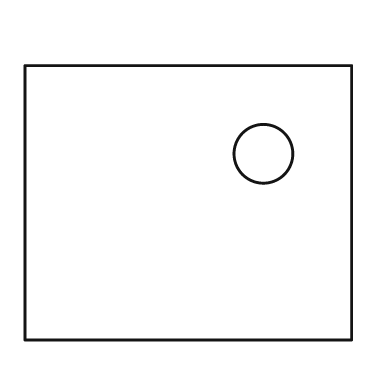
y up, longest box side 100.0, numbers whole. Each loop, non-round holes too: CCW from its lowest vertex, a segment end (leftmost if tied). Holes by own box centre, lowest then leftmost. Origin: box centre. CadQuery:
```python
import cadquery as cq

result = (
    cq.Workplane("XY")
    .moveTo(-50.0, -42.0)
    .lineTo(50.0, -42.0)
    .lineTo(50.0, 42.0)
    .lineTo(-50.0, 42.0)
    .close()
    .moveTo(23.0, 15.0)
    .circle(9.0)
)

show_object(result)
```